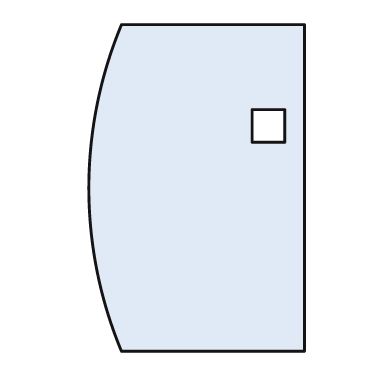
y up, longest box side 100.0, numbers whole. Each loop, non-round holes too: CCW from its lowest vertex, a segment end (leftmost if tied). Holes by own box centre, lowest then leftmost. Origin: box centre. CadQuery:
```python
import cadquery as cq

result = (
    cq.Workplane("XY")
    .moveTo(-23.0, -50.0)
    .lineTo(33.0, -50.0)
    .lineTo(33.0, 50.0)
    .lineTo(-23.0, 50.0)
    .threePointArc((-33.0, 0.0), (-23.0, -50.0))
    .close()
    .moveTo(17.0, 14.0)
    .lineTo(27.0, 14.0)
    .lineTo(27.0, 24.0)
    .lineTo(17.0, 24.0)
    .close()
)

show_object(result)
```